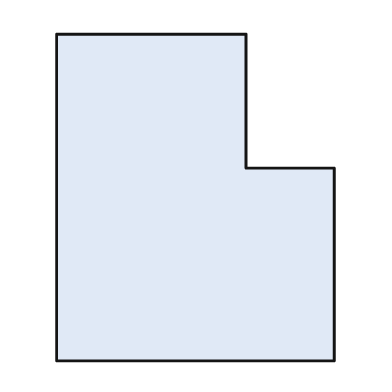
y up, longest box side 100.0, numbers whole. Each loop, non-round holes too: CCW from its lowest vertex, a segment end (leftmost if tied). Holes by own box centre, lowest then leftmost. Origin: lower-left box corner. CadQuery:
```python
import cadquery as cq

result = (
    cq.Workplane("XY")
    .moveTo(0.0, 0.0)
    .lineTo(85.0, 0.0)
    .lineTo(85.0, 59.0)
    .lineTo(58.0, 59.0)
    .lineTo(58.0, 100.0)
    .lineTo(0.0, 100.0)
    .close()
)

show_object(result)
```